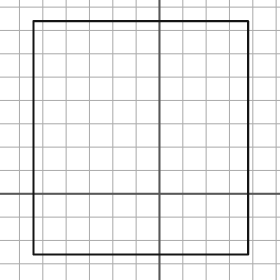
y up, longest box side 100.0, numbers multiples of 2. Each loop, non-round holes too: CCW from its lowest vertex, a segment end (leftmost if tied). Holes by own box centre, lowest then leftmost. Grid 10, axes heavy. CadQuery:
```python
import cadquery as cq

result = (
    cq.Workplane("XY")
    .moveTo(-54.0, -26.0)
    .lineTo(38.0, -26.0)
    .lineTo(38.0, 74.0)
    .lineTo(-54.0, 74.0)
    .close()
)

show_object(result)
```